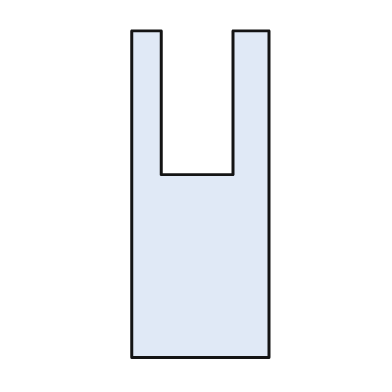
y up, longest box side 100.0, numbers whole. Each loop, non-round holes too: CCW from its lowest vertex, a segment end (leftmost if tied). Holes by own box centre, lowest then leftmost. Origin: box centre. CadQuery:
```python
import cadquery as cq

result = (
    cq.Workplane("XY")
    .moveTo(-21.0, -50.0)
    .lineTo(21.0, -50.0)
    .lineTo(21.0, 50.0)
    .lineTo(10.0, 50.0)
    .lineTo(10.0, 6.0)
    .lineTo(-12.0, 6.0)
    .lineTo(-12.0, 50.0)
    .lineTo(-21.0, 50.0)
    .close()
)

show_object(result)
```